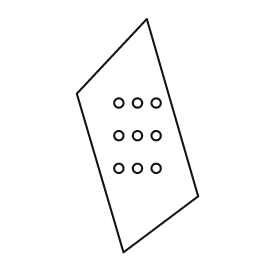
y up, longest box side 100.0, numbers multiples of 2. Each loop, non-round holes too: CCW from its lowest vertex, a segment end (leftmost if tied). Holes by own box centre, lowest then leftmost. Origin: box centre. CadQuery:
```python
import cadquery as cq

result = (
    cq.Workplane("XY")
    .moveTo(-6.0, -50.0)
    .lineTo(26.0, -26.0)
    .lineTo(4.0, 50.0)
    .lineTo(-26.0, 18.0)
    .close()
    .moveTo(-8.0, -14.0)
    .circle(2.0)
    .moveTo(0.0, -14.0)
    .circle(2.0)
    .moveTo(8.0, -14.0)
    .circle(2.0)
    .moveTo(-8.0, 0.0)
    .circle(2.0)
    .moveTo(0.0, 0.0)
    .circle(2.0)
    .moveTo(8.0, 0.0)
    .circle(2.0)
    .moveTo(-8.0, 14.0)
    .circle(2.0)
    .moveTo(0.0, 14.0)
    .circle(2.0)
    .moveTo(8.0, 14.0)
    .circle(2.0)
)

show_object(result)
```